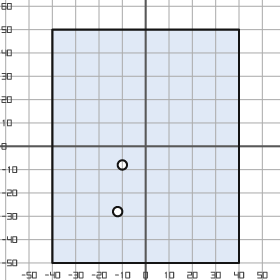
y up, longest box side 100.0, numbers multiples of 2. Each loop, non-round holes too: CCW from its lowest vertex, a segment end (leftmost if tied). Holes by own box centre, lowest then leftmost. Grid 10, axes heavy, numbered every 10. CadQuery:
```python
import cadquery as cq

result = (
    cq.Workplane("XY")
    .moveTo(-40.0, -50.0)
    .lineTo(40.0, -50.0)
    .lineTo(40.0, 50.0)
    .lineTo(-40.0, 50.0)
    .close()
    .moveTo(-12.0, -28.0)
    .circle(2.0)
    .moveTo(-10.0, -8.0)
    .circle(2.0)
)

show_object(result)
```